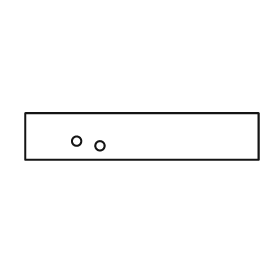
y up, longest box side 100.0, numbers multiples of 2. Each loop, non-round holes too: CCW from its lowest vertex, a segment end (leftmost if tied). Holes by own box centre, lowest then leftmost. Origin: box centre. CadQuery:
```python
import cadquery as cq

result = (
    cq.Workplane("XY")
    .moveTo(-50.0, -10.0)
    .lineTo(50.0, -10.0)
    .lineTo(50.0, 10.0)
    .lineTo(-50.0, 10.0)
    .close()
    .moveTo(-18.0, -4.0)
    .circle(2.0)
    .moveTo(-28.0, -2.0)
    .circle(2.0)
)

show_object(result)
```